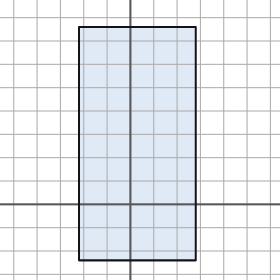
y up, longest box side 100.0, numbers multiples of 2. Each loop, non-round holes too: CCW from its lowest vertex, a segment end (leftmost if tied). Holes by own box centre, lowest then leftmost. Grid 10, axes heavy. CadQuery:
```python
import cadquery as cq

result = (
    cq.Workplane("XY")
    .moveTo(-22.0, -24.0)
    .lineTo(28.0, -24.0)
    .lineTo(28.0, 76.0)
    .lineTo(-22.0, 76.0)
    .close()
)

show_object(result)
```